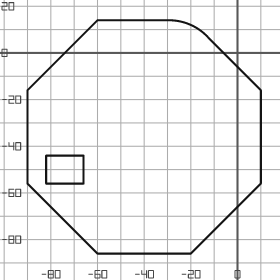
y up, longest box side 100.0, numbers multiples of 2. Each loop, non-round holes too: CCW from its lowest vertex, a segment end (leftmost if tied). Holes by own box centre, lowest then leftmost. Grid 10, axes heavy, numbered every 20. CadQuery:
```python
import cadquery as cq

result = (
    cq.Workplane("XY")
    .moveTo(-60.0, -86.0)
    .lineTo(-20.0, -86.0)
    .lineTo(10.0, -56.0)
    .lineTo(10.0, -16.0)
    .lineTo(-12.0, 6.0)
    .threePointArc((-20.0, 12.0), (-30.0, 14.0))
    .lineTo(-60.0, 14.0)
    .lineTo(-90.0, -16.0)
    .lineTo(-90.0, -56.0)
    .close()
    .moveTo(-82.0, -56.0)
    .lineTo(-66.0, -56.0)
    .lineTo(-66.0, -44.0)
    .lineTo(-82.0, -44.0)
    .close()
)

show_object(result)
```